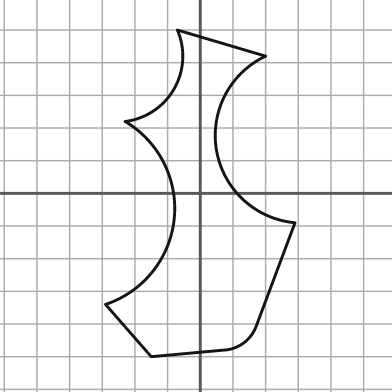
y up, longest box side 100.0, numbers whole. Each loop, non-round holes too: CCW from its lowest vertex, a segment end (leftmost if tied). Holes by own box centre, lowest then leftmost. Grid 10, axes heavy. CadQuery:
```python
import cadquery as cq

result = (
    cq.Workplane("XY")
    .moveTo(-15.0, -50.0)
    .lineTo(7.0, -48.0)
    .threePointArc((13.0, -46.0), (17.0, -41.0))
    .lineTo(29.0, -9.0)
    .threePointArc((5.0, 13.0), (20.0, 42.0))
    .lineTo(-7.0, 50.0)
    .threePointArc((-8.0, 32.0), (-23.0, 22.0))
    .threePointArc((-8.0, -8.0), (-29.0, -34.0))
    .close()
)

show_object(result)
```